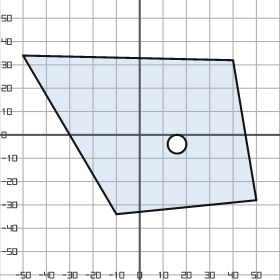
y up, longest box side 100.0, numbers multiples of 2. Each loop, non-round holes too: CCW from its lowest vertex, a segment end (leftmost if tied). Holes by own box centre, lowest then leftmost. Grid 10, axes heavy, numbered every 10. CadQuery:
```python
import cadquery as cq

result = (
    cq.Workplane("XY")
    .moveTo(-10.0, -34.0)
    .lineTo(50.0, -28.0)
    .lineTo(40.0, 32.0)
    .lineTo(-50.0, 34.0)
    .close()
    .moveTo(16.0, -4.0)
    .circle(4.0)
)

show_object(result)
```